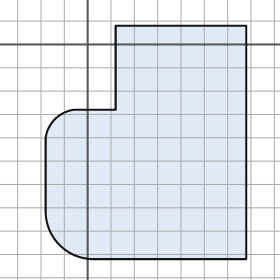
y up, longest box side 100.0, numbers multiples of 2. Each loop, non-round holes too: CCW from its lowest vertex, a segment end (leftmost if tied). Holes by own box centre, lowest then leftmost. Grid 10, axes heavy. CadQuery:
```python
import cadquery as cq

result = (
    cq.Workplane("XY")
    .moveTo(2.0, -92.0)
    .lineTo(68.0, -92.0)
    .lineTo(68.0, 8.0)
    .lineTo(12.0, 8.0)
    .lineTo(12.0, -28.0)
    .lineTo(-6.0, -28.0)
    .threePointArc((-14.0, -32.0), (-18.0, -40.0))
    .lineTo(-18.0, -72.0)
    .threePointArc((-12.0, -86.0), (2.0, -92.0))
    .close()
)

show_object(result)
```